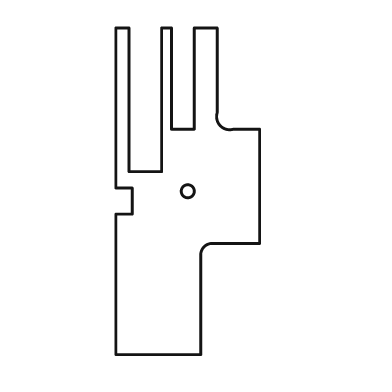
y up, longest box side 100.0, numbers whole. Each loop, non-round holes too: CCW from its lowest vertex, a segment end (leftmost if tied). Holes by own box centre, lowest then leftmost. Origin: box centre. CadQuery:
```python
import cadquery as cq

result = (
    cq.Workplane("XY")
    .moveTo(-22.0, -50.0)
    .lineTo(4.0, -50.0)
    .lineTo(4.0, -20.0)
    .threePointArc((5.0, -17.0), (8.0, -16.0))
    .lineTo(22.0, -16.0)
    .lineTo(22.0, 19.0)
    .lineTo(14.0, 19.0)
    .threePointArc((10.0, 20.0), (9.0, 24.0))
    .lineTo(9.0, 50.0)
    .lineTo(2.0, 50.0)
    .lineTo(2.0, 19.0)
    .lineTo(-5.0, 19.0)
    .lineTo(-5.0, 50.0)
    .lineTo(-8.0, 50.0)
    .lineTo(-8.0, 6.0)
    .lineTo(-18.0, 6.0)
    .lineTo(-18.0, 50.0)
    .lineTo(-22.0, 50.0)
    .lineTo(-22.0, 1.0)
    .lineTo(-17.0, 1.0)
    .lineTo(-17.0, -7.0)
    .lineTo(-22.0, -7.0)
    .close()
    .moveTo(0.0, 0.0)
    .circle(2.0)
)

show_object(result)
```